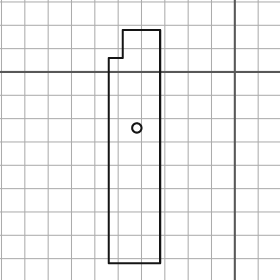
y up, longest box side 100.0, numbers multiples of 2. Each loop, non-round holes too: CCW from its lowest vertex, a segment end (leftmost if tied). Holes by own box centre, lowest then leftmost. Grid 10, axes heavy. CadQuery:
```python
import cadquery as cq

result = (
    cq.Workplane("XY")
    .moveTo(-54.0, -82.0)
    .lineTo(-32.0, -82.0)
    .lineTo(-32.0, 18.0)
    .lineTo(-48.0, 18.0)
    .lineTo(-48.0, 6.0)
    .lineTo(-54.0, 6.0)
    .close()
    .moveTo(-42.0, -24.0)
    .circle(2.0)
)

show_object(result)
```